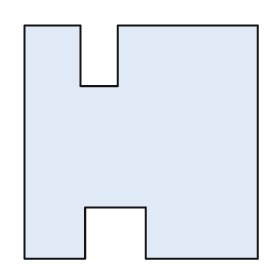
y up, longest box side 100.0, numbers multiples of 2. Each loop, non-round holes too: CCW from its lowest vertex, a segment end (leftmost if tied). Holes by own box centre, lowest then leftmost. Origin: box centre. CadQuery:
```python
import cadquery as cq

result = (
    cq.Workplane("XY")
    .moveTo(-50.0, -50.0)
    .lineTo(-24.0, -50.0)
    .lineTo(-24.0, -28.0)
    .lineTo(2.0, -28.0)
    .lineTo(2.0, -50.0)
    .lineTo(50.0, -50.0)
    .lineTo(50.0, 50.0)
    .lineTo(-10.0, 50.0)
    .lineTo(-10.0, 24.0)
    .lineTo(-26.0, 24.0)
    .lineTo(-26.0, 50.0)
    .lineTo(-50.0, 50.0)
    .close()
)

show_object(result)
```